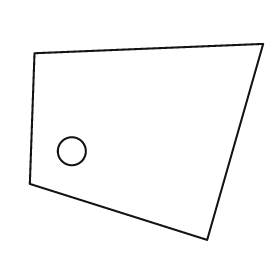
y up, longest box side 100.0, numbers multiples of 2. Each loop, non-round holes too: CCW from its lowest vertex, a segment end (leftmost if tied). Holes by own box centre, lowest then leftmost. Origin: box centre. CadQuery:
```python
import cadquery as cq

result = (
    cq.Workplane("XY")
    .moveTo(26.0, -42.0)
    .lineTo(50.0, 42.0)
    .lineTo(-48.0, 38.0)
    .lineTo(-50.0, -18.0)
    .close()
    .moveTo(-32.0, -4.0)
    .circle(6.0)
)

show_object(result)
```